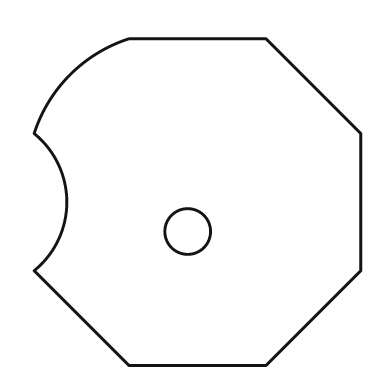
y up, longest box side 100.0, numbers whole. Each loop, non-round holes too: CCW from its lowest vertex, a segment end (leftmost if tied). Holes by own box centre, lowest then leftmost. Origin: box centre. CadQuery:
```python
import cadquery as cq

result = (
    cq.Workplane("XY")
    .moveTo(-21.0, -50.0)
    .lineTo(21.0, -50.0)
    .lineTo(50.0, -21.0)
    .lineTo(50.0, 21.0)
    .lineTo(21.0, 50.0)
    .lineTo(-21.0, 50.0)
    .threePointArc((-39.0, 39.0), (-50.0, 21.0))
    .threePointArc((-40.0, 0.0), (-50.0, -21.0))
    .close()
    .moveTo(-3.0, -9.0)
    .circle(7.0)
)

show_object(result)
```